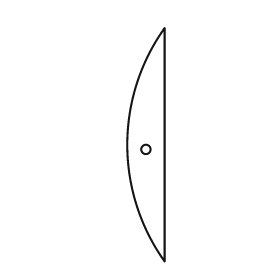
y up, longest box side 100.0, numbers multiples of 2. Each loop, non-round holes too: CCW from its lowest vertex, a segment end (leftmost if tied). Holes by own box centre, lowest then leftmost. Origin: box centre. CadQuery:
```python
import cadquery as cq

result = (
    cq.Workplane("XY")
    .moveTo(8.0, -50.0)
    .lineTo(8.0, 50.0)
    .threePointArc((-8.0, 0.0), (8.0, -50.0))
    .close()
    .moveTo(0.0, -2.0)
    .circle(2.0)
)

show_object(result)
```